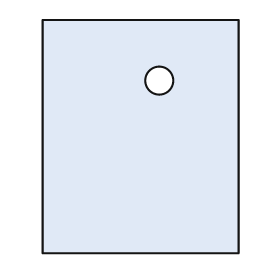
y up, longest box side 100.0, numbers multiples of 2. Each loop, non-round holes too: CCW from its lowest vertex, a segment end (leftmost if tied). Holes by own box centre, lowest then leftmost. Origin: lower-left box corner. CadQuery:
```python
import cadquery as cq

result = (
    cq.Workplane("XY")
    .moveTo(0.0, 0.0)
    .lineTo(84.0, 0.0)
    .lineTo(84.0, 100.0)
    .lineTo(0.0, 100.0)
    .close()
    .moveTo(50.0, 74.0)
    .circle(6.0)
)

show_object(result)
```